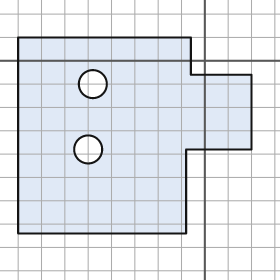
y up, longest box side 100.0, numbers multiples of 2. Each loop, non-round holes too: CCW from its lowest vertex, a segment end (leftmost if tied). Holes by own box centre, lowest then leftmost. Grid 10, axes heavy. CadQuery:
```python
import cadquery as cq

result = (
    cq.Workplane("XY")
    .moveTo(-80.0, -74.0)
    .lineTo(-8.0, -74.0)
    .lineTo(-8.0, -38.0)
    .lineTo(20.0, -38.0)
    .lineTo(20.0, -6.0)
    .lineTo(-6.0, -6.0)
    .lineTo(-6.0, 10.0)
    .lineTo(-80.0, 10.0)
    .close()
    .moveTo(-50.0, -38.0)
    .circle(6.0)
    .moveTo(-48.0, -10.0)
    .circle(6.0)
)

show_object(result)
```